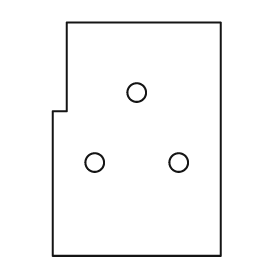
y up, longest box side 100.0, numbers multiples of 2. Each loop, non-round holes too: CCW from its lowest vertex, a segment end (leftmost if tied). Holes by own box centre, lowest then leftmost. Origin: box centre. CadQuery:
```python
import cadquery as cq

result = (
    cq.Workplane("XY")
    .moveTo(-36.0, -50.0)
    .lineTo(36.0, -50.0)
    .lineTo(36.0, 50.0)
    .lineTo(-30.0, 50.0)
    .lineTo(-30.0, 12.0)
    .lineTo(-36.0, 12.0)
    .close()
    .moveTo(-18.0, -10.0)
    .circle(4.0)
    .moveTo(18.0, -10.0)
    .circle(4.0)
    .moveTo(0.0, 20.0)
    .circle(4.0)
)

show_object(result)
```